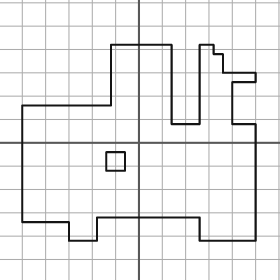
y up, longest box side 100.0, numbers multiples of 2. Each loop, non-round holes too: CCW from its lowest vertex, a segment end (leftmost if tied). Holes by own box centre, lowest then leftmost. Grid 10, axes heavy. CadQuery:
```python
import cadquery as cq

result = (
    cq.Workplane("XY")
    .moveTo(-30.0, -42.0)
    .lineTo(-18.0, -42.0)
    .lineTo(-18.0, -32.0)
    .lineTo(26.0, -32.0)
    .lineTo(26.0, -42.0)
    .lineTo(50.0, -42.0)
    .lineTo(50.0, 8.0)
    .lineTo(40.0, 8.0)
    .lineTo(40.0, 26.0)
    .lineTo(50.0, 26.0)
    .lineTo(50.0, 30.0)
    .lineTo(36.0, 30.0)
    .lineTo(36.0, 38.0)
    .lineTo(32.0, 38.0)
    .lineTo(32.0, 42.0)
    .lineTo(26.0, 42.0)
    .lineTo(26.0, 8.0)
    .lineTo(14.0, 8.0)
    .lineTo(14.0, 42.0)
    .lineTo(-12.0, 42.0)
    .lineTo(-12.0, 16.0)
    .lineTo(-50.0, 16.0)
    .lineTo(-50.0, -34.0)
    .lineTo(-30.0, -34.0)
    .close()
    .moveTo(-14.0, -12.0)
    .lineTo(-6.0, -12.0)
    .lineTo(-6.0, -4.0)
    .lineTo(-14.0, -4.0)
    .close()
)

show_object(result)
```